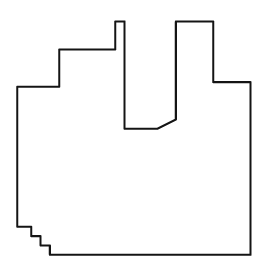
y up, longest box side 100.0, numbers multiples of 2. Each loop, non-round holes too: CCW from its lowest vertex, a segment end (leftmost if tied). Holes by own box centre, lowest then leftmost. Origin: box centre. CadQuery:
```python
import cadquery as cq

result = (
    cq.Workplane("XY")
    .moveTo(-36.0, -50.0)
    .lineTo(50.0, -50.0)
    .lineTo(50.0, 24.0)
    .lineTo(34.0, 24.0)
    .lineTo(34.0, 50.0)
    .lineTo(18.0, 50.0)
    .lineTo(18.0, 8.0)
    .lineTo(10.0, 4.0)
    .lineTo(-4.0, 4.0)
    .lineTo(-4.0, 50.0)
    .lineTo(-8.0, 50.0)
    .lineTo(-8.0, 38.0)
    .lineTo(-32.0, 38.0)
    .lineTo(-32.0, 22.0)
    .lineTo(-50.0, 22.0)
    .lineTo(-50.0, -38.0)
    .lineTo(-44.0, -38.0)
    .lineTo(-44.0, -42.0)
    .lineTo(-40.0, -42.0)
    .lineTo(-40.0, -46.0)
    .lineTo(-36.0, -46.0)
    .close()
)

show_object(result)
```